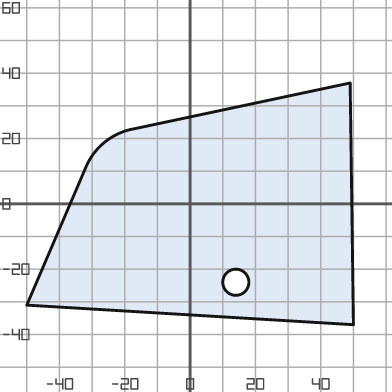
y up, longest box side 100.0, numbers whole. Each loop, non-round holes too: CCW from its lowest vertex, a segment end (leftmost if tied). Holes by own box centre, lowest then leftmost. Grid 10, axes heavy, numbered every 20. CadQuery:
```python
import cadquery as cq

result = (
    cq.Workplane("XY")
    .moveTo(50.0, -37.0)
    .lineTo(49.0, 37.0)
    .lineTo(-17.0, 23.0)
    .threePointArc((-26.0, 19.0), (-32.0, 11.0))
    .lineTo(-50.0, -31.0)
    .close()
    .moveTo(14.0, -24.0)
    .circle(4.0)
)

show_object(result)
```